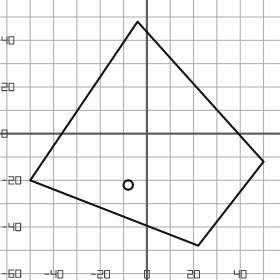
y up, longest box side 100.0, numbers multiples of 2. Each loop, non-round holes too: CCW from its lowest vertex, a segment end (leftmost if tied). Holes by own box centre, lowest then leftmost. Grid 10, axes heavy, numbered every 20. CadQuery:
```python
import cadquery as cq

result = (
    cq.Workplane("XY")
    .moveTo(22.0, -48.0)
    .lineTo(50.0, -12.0)
    .lineTo(-4.0, 48.0)
    .lineTo(-50.0, -20.0)
    .close()
    .moveTo(-8.0, -22.0)
    .circle(2.0)
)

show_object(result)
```